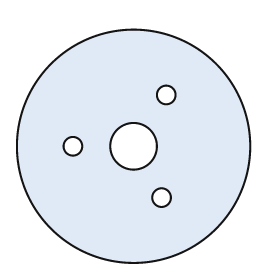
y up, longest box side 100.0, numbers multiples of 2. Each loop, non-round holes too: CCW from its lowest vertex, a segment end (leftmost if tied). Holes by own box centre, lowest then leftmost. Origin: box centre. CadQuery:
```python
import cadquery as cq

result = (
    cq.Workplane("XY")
    .moveTo(0.0, 0.0)
    .circle(50.0)
    .moveTo(12.0, -22.0)
    .circle(4.0)
    .moveTo(-26.0, 0.0)
    .circle(4.0)
    .moveTo(0.0, 0.0)
    .circle(10.0)
    .moveTo(14.0, 22.0)
    .circle(4.0)
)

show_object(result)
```